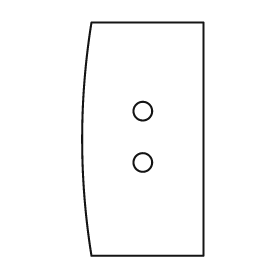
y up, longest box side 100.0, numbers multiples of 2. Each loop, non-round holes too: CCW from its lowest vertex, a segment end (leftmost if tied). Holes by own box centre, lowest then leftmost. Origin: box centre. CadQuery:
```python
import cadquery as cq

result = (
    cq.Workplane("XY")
    .moveTo(-22.0, -50.0)
    .lineTo(26.0, -50.0)
    .lineTo(26.0, 50.0)
    .lineTo(-22.0, 50.0)
    .threePointArc((-26.0, 0.0), (-22.0, -50.0))
    .close()
    .moveTo(0.0, -10.0)
    .circle(4.0)
    .moveTo(0.0, 12.0)
    .circle(4.0)
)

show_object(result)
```